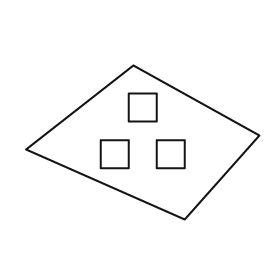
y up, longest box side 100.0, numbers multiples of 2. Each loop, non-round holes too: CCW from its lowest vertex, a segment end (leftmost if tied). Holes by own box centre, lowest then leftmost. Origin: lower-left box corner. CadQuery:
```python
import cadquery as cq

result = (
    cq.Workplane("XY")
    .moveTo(68.0, 0.0)
    .lineTo(100.0, 36.0)
    .lineTo(46.0, 66.0)
    .lineTo(0.0, 30.0)
    .close()
    .moveTo(32.0, 22.0)
    .lineTo(44.0, 22.0)
    .lineTo(44.0, 34.0)
    .lineTo(32.0, 34.0)
    .close()
    .moveTo(56.0, 22.0)
    .lineTo(68.0, 22.0)
    .lineTo(68.0, 34.0)
    .lineTo(56.0, 34.0)
    .close()
    .moveTo(44.0, 42.0)
    .lineTo(56.0, 42.0)
    .lineTo(56.0, 54.0)
    .lineTo(44.0, 54.0)
    .close()
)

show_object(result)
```